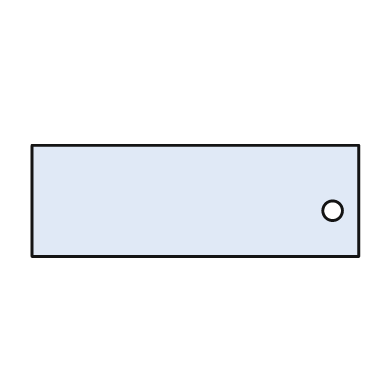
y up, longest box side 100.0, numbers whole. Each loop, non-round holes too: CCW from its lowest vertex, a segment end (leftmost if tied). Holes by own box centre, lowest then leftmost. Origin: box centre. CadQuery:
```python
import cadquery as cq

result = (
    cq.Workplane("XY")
    .moveTo(-50.0, -17.0)
    .lineTo(50.0, -17.0)
    .lineTo(50.0, 17.0)
    .lineTo(-50.0, 17.0)
    .close()
    .moveTo(42.0, -3.0)
    .circle(3.0)
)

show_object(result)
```